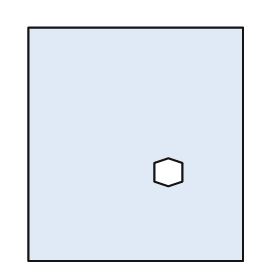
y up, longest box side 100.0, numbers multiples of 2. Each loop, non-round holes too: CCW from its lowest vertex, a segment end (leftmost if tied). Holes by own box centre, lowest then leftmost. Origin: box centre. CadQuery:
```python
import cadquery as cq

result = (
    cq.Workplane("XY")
    .moveTo(-46.0, -50.0)
    .lineTo(46.0, -50.0)
    .lineTo(46.0, 50.0)
    .lineTo(-46.0, 50.0)
    .close()
    .moveTo(14.0, -18.0)
    .lineTo(20.0, -16.0)
    .lineTo(20.0, -8.0)
    .lineTo(14.0, -6.0)
    .lineTo(8.0, -8.0)
    .lineTo(8.0, -16.0)
    .close()
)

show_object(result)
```